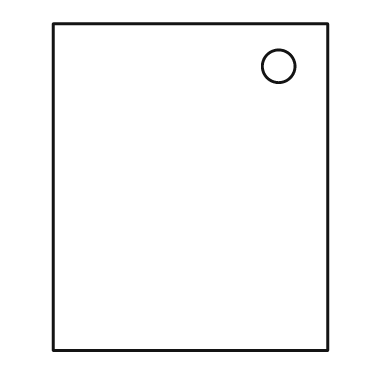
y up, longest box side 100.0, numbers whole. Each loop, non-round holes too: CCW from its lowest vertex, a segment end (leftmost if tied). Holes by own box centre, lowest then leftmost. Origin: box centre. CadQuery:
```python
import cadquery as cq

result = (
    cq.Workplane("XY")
    .moveTo(-42.0, -50.0)
    .lineTo(42.0, -50.0)
    .lineTo(42.0, 50.0)
    .lineTo(-42.0, 50.0)
    .close()
    .moveTo(27.0, 37.0)
    .circle(5.0)
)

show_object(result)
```